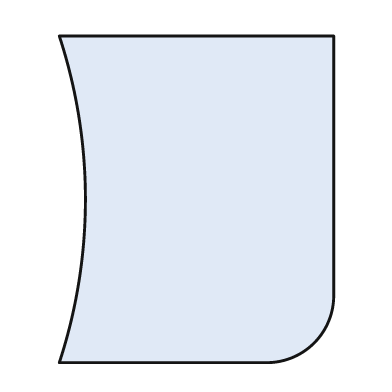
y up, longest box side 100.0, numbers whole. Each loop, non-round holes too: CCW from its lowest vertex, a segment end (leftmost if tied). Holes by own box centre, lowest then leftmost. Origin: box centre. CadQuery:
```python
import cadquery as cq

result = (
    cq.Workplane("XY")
    .moveTo(-42.0, -50.0)
    .lineTo(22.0, -50.0)
    .threePointArc((36.0, -44.0), (42.0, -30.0))
    .lineTo(42.0, 50.0)
    .lineTo(-42.0, 50.0)
    .threePointArc((-34.0, 0.0), (-42.0, -50.0))
    .close()
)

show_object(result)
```